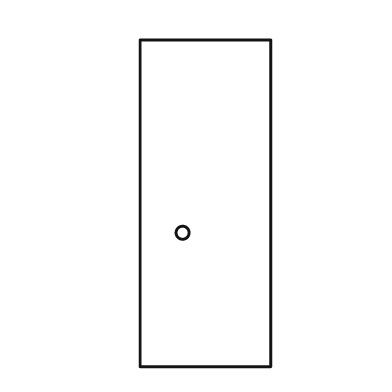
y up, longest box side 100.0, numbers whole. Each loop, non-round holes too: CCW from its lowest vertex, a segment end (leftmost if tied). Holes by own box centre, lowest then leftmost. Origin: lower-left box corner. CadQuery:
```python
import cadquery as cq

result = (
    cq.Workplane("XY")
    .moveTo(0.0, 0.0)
    .lineTo(40.0, 0.0)
    .lineTo(40.0, 100.0)
    .lineTo(0.0, 100.0)
    .close()
    .moveTo(13.0, 41.0)
    .circle(2.0)
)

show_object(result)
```